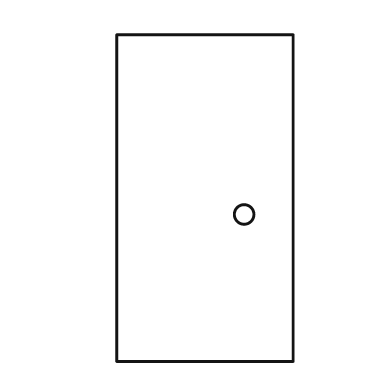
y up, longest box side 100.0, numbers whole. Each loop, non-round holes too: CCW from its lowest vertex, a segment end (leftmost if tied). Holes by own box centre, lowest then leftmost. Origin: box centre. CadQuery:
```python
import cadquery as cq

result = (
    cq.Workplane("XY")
    .moveTo(-27.0, -50.0)
    .lineTo(27.0, -50.0)
    .lineTo(27.0, 50.0)
    .lineTo(-27.0, 50.0)
    .close()
    .moveTo(12.0, -5.0)
    .circle(3.0)
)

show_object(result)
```